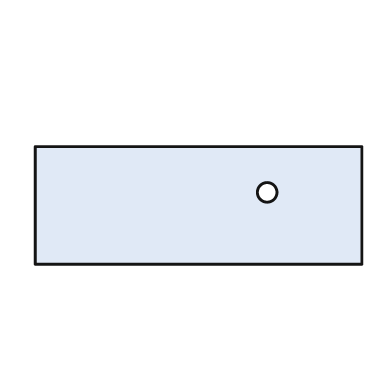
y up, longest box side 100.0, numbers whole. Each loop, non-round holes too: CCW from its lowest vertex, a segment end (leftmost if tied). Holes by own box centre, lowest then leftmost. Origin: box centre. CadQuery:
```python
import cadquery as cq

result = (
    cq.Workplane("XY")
    .moveTo(-50.0, -18.0)
    .lineTo(50.0, -18.0)
    .lineTo(50.0, 18.0)
    .lineTo(-50.0, 18.0)
    .close()
    .moveTo(21.0, 4.0)
    .circle(3.0)
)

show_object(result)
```